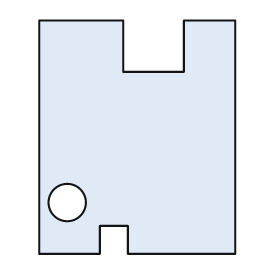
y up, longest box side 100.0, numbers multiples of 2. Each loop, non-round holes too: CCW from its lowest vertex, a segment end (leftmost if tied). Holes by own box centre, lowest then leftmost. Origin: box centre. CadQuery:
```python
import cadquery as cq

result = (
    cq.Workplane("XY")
    .moveTo(-42.0, -50.0)
    .lineTo(-16.0, -50.0)
    .lineTo(-16.0, -38.0)
    .lineTo(-4.0, -38.0)
    .lineTo(-4.0, -50.0)
    .lineTo(42.0, -50.0)
    .lineTo(42.0, 50.0)
    .lineTo(20.0, 50.0)
    .lineTo(20.0, 28.0)
    .lineTo(-6.0, 28.0)
    .lineTo(-6.0, 50.0)
    .lineTo(-42.0, 50.0)
    .close()
    .moveTo(-30.0, -28.0)
    .circle(8.0)
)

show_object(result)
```